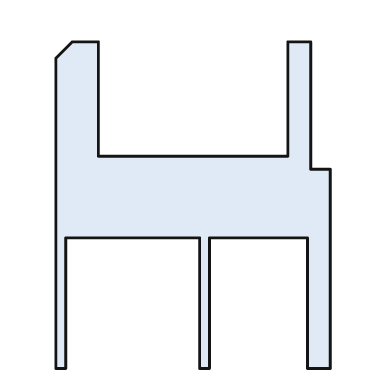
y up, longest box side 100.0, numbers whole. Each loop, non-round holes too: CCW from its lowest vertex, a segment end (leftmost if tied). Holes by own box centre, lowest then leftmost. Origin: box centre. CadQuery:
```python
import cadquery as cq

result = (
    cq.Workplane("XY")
    .moveTo(-42.0, -50.0)
    .lineTo(-39.0, -50.0)
    .lineTo(-39.0, -10.0)
    .lineTo(2.0, -10.0)
    .lineTo(2.0, -50.0)
    .lineTo(5.0, -50.0)
    .lineTo(5.0, -10.0)
    .lineTo(35.0, -10.0)
    .lineTo(35.0, -50.0)
    .lineTo(42.0, -50.0)
    .lineTo(42.0, 11.0)
    .lineTo(36.0, 11.0)
    .lineTo(36.0, 50.0)
    .lineTo(29.0, 50.0)
    .lineTo(29.0, 15.0)
    .lineTo(-29.0, 15.0)
    .lineTo(-29.0, 50.0)
    .lineTo(-37.0, 50.0)
    .lineTo(-42.0, 45.0)
    .close()
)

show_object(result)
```